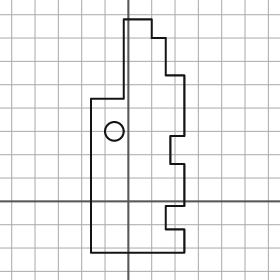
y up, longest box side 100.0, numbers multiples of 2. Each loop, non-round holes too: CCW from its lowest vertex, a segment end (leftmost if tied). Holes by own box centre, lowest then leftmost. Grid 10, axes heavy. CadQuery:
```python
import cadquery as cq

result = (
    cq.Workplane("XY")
    .moveTo(-16.0, -22.0)
    .lineTo(24.0, -22.0)
    .lineTo(24.0, -12.0)
    .lineTo(16.0, -12.0)
    .lineTo(16.0, -2.0)
    .lineTo(24.0, -2.0)
    .lineTo(24.0, 16.0)
    .lineTo(18.0, 16.0)
    .lineTo(18.0, 28.0)
    .lineTo(24.0, 28.0)
    .lineTo(24.0, 54.0)
    .lineTo(16.0, 54.0)
    .lineTo(16.0, 70.0)
    .lineTo(10.0, 70.0)
    .lineTo(10.0, 78.0)
    .lineTo(-2.0, 78.0)
    .lineTo(-2.0, 44.0)
    .lineTo(-16.0, 44.0)
    .close()
    .moveTo(-6.0, 30.0)
    .circle(4.0)
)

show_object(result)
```